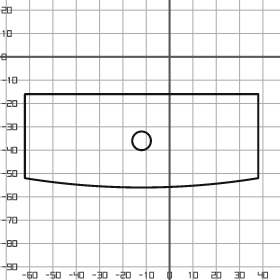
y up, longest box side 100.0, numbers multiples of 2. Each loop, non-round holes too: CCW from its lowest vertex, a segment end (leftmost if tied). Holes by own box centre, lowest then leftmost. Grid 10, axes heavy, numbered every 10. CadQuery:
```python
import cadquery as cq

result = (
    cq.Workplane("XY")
    .moveTo(-62.0, -52.0)
    .threePointArc((-12.0, -56.0), (38.0, -52.0))
    .lineTo(38.0, -16.0)
    .lineTo(-62.0, -16.0)
    .close()
    .moveTo(-12.0, -36.0)
    .circle(4.0)
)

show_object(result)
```